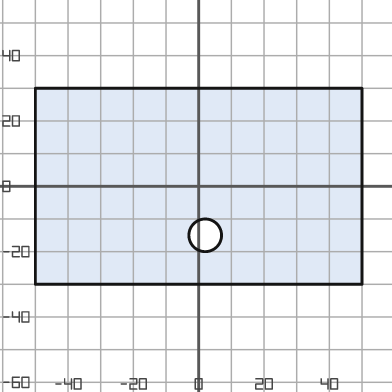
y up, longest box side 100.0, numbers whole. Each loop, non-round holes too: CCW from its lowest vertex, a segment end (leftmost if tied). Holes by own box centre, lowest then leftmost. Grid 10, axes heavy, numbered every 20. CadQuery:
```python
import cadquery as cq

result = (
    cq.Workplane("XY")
    .moveTo(-50.0, -30.0)
    .lineTo(50.0, -30.0)
    .lineTo(50.0, 30.0)
    .lineTo(-50.0, 30.0)
    .close()
    .moveTo(2.0, -15.0)
    .circle(5.0)
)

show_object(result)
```